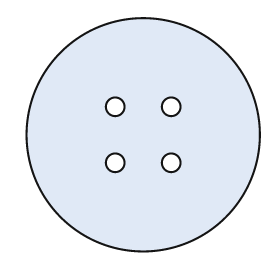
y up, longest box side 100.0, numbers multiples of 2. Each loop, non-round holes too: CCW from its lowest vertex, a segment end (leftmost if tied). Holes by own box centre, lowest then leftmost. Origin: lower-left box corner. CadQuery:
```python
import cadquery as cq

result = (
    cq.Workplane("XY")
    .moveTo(50.0, 50.0)
    .circle(50.0)
    .moveTo(38.0, 38.0)
    .circle(4.0)
    .moveTo(62.0, 38.0)
    .circle(4.0)
    .moveTo(38.0, 62.0)
    .circle(4.0)
    .moveTo(62.0, 62.0)
    .circle(4.0)
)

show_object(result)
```